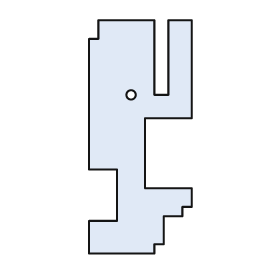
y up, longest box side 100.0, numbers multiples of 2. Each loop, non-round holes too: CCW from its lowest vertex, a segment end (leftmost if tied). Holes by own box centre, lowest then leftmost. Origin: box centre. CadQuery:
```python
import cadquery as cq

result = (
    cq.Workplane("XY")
    .moveTo(-22.0, -50.0)
    .lineTo(6.0, -50.0)
    .lineTo(6.0, -46.0)
    .lineTo(10.0, -46.0)
    .lineTo(10.0, -34.0)
    .lineTo(18.0, -34.0)
    .lineTo(18.0, -30.0)
    .lineTo(22.0, -30.0)
    .lineTo(22.0, -22.0)
    .lineTo(2.0, -22.0)
    .lineTo(2.0, 8.0)
    .lineTo(22.0, 8.0)
    .lineTo(22.0, 50.0)
    .lineTo(12.0, 50.0)
    .lineTo(12.0, 18.0)
    .lineTo(6.0, 18.0)
    .lineTo(6.0, 50.0)
    .lineTo(-18.0, 50.0)
    .lineTo(-18.0, 42.0)
    .lineTo(-22.0, 42.0)
    .lineTo(-22.0, -14.0)
    .lineTo(-10.0, -14.0)
    .lineTo(-10.0, -36.0)
    .lineTo(-22.0, -36.0)
    .close()
    .moveTo(-4.0, 18.0)
    .circle(2.0)
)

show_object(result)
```